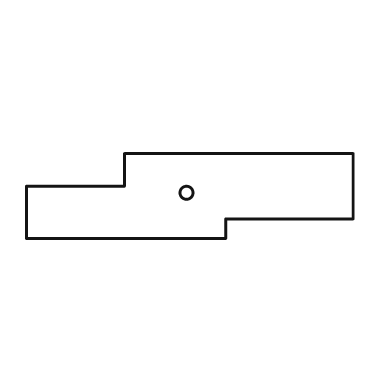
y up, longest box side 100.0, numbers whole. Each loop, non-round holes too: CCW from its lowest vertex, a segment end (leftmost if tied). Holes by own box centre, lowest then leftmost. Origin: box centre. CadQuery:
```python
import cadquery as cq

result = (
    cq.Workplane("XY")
    .moveTo(-50.0, -13.0)
    .lineTo(11.0, -13.0)
    .lineTo(11.0, -7.0)
    .lineTo(50.0, -7.0)
    .lineTo(50.0, 13.0)
    .lineTo(-20.0, 13.0)
    .lineTo(-20.0, 3.0)
    .lineTo(-50.0, 3.0)
    .close()
    .moveTo(-1.0, 1.0)
    .circle(2.0)
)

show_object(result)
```